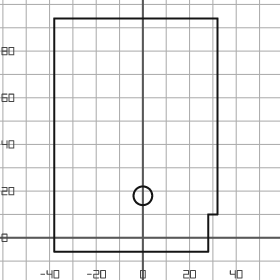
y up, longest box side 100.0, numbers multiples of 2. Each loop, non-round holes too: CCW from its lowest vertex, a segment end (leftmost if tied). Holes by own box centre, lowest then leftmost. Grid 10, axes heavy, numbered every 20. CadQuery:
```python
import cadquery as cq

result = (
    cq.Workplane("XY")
    .moveTo(-38.0, -6.0)
    .lineTo(28.0, -6.0)
    .lineTo(28.0, 10.0)
    .lineTo(32.0, 10.0)
    .lineTo(32.0, 94.0)
    .lineTo(-38.0, 94.0)
    .close()
    .moveTo(0.0, 18.0)
    .circle(4.0)
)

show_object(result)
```